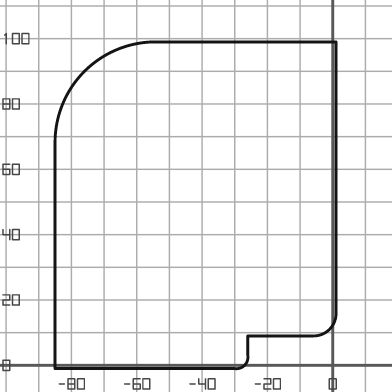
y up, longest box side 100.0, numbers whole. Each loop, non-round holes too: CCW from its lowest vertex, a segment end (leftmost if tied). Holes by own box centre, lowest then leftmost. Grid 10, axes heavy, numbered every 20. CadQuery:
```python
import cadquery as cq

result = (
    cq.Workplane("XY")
    .moveTo(-85.0, -1.0)
    .lineTo(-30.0, -1.0)
    .threePointArc((-27.0, 0.0), (-26.0, 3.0))
    .lineTo(-26.0, 9.0)
    .lineTo(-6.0, 9.0)
    .threePointArc((-1.0, 11.0), (1.0, 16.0))
    .lineTo(1.0, 99.0)
    .lineTo(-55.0, 99.0)
    .threePointArc((-76.0, 90.0), (-85.0, 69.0))
    .close()
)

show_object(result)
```